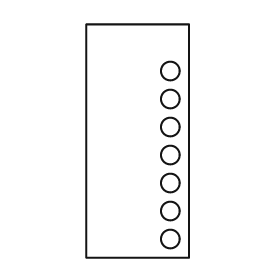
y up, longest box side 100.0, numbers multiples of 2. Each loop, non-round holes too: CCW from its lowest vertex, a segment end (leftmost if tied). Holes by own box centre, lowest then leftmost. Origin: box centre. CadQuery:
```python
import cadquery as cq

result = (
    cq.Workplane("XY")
    .moveTo(-22.0, -50.0)
    .lineTo(22.0, -50.0)
    .lineTo(22.0, 50.0)
    .lineTo(-22.0, 50.0)
    .close()
    .moveTo(14.0, -42.0)
    .circle(4.0)
    .moveTo(14.0, -30.0)
    .circle(4.0)
    .moveTo(14.0, -18.0)
    .circle(4.0)
    .moveTo(14.0, -6.0)
    .circle(4.0)
    .moveTo(14.0, 6.0)
    .circle(4.0)
    .moveTo(14.0, 18.0)
    .circle(4.0)
    .moveTo(14.0, 30.0)
    .circle(4.0)
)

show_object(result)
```